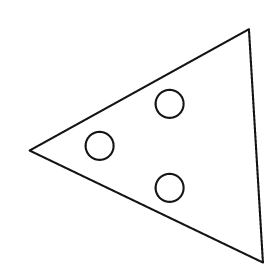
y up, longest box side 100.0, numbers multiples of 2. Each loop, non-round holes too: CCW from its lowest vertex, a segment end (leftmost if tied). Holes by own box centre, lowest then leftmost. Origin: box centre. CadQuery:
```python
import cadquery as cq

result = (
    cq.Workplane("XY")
    .moveTo(50.0, -50.0)
    .lineTo(44.0, 50.0)
    .lineTo(-50.0, -2.0)
    .close()
    .moveTo(10.0, -18.0)
    .circle(6.0)
    .moveTo(-20.0, 0.0)
    .circle(6.0)
    .moveTo(10.0, 18.0)
    .circle(6.0)
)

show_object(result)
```